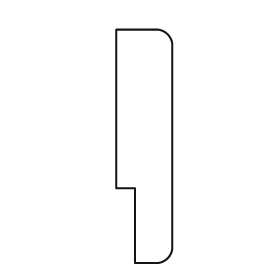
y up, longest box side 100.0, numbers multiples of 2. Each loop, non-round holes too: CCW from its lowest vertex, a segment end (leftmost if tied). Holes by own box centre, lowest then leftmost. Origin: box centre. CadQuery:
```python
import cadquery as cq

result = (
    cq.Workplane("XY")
    .moveTo(-4.0, -50.0)
    .lineTo(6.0, -50.0)
    .threePointArc((10.0, -48.0), (12.0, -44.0))
    .lineTo(12.0, 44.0)
    .threePointArc((10.0, 48.0), (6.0, 50.0))
    .lineTo(-12.0, 50.0)
    .lineTo(-12.0, -18.0)
    .lineTo(-4.0, -18.0)
    .close()
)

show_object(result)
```